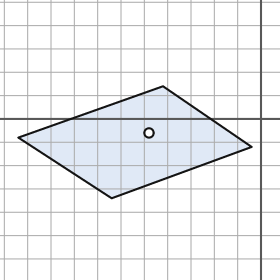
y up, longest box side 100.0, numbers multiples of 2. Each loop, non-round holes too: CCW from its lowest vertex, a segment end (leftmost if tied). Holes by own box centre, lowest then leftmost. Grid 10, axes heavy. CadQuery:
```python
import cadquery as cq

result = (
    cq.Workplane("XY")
    .moveTo(-64.0, -34.0)
    .lineTo(-4.0, -12.0)
    .lineTo(-42.0, 14.0)
    .lineTo(-104.0, -8.0)
    .close()
    .moveTo(-48.0, -6.0)
    .circle(2.0)
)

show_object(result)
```